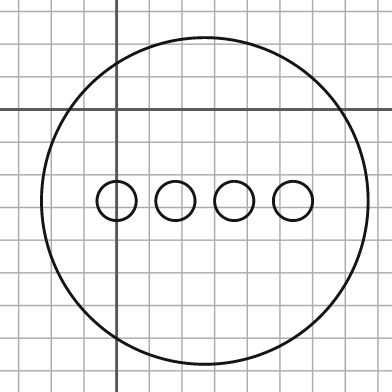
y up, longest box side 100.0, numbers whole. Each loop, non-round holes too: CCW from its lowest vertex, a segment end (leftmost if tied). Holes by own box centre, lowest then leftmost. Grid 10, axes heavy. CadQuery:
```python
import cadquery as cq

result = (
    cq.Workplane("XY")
    .moveTo(27.0, -28.0)
    .circle(50.0)
    .moveTo(0.0, -28.0)
    .circle(6.0)
    .moveTo(18.0, -28.0)
    .circle(6.0)
    .moveTo(36.0, -28.0)
    .circle(6.0)
    .moveTo(54.0, -28.0)
    .circle(6.0)
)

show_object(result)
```